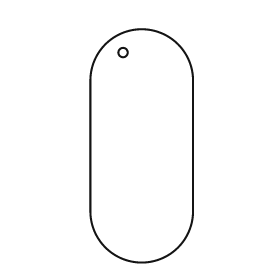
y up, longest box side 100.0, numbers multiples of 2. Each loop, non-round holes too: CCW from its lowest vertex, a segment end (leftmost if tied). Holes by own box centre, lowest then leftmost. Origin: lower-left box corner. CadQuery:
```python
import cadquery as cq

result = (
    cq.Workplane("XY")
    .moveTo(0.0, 22.0)
    .threePointArc((22.0, 0.0), (44.0, 22.0))
    .lineTo(44.0, 78.0)
    .threePointArc((22.0, 100.0), (0.0, 78.0))
    .close()
    .moveTo(14.0, 90.0)
    .circle(2.0)
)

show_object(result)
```